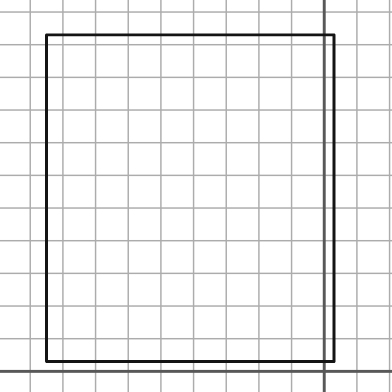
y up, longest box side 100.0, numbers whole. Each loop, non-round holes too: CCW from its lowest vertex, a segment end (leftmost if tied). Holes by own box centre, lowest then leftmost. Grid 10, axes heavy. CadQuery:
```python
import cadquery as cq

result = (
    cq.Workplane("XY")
    .moveTo(-85.0, 3.0)
    .lineTo(3.0, 3.0)
    .lineTo(3.0, 103.0)
    .lineTo(-85.0, 103.0)
    .close()
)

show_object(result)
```